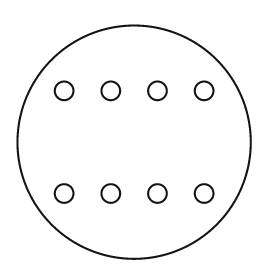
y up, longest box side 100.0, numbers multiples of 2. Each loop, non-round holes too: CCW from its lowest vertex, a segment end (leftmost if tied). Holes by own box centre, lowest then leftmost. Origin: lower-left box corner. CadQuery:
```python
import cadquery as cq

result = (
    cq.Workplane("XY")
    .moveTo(50.0, 50.0)
    .circle(50.0)
    .moveTo(20.0, 28.0)
    .circle(4.0)
    .moveTo(40.0, 28.0)
    .circle(4.0)
    .moveTo(60.0, 28.0)
    .circle(4.0)
    .moveTo(80.0, 28.0)
    .circle(4.0)
    .moveTo(20.0, 72.0)
    .circle(4.0)
    .moveTo(40.0, 72.0)
    .circle(4.0)
    .moveTo(60.0, 72.0)
    .circle(4.0)
    .moveTo(80.0, 72.0)
    .circle(4.0)
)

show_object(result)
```